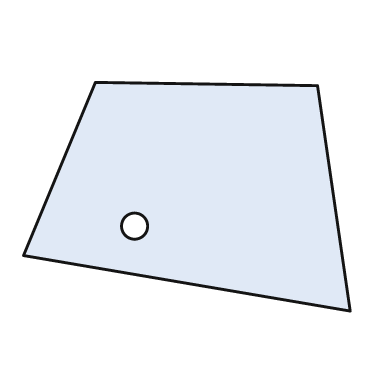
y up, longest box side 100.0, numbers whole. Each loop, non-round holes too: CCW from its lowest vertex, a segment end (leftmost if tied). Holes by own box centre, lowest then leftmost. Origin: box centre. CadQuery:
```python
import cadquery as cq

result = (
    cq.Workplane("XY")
    .moveTo(50.0, -35.0)
    .lineTo(40.0, 34.0)
    .lineTo(-28.0, 35.0)
    .lineTo(-50.0, -18.0)
    .close()
    .moveTo(-16.0, -9.0)
    .circle(4.0)
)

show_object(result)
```